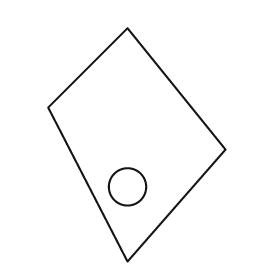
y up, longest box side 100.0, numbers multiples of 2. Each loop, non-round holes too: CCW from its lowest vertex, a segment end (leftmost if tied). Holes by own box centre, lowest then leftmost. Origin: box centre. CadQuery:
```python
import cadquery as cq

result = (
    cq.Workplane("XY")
    .moveTo(-4.0, -50.0)
    .lineTo(38.0, -2.0)
    .lineTo(-4.0, 50.0)
    .lineTo(-38.0, 16.0)
    .close()
    .moveTo(-4.0, -18.0)
    .circle(8.0)
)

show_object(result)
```